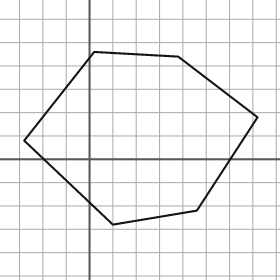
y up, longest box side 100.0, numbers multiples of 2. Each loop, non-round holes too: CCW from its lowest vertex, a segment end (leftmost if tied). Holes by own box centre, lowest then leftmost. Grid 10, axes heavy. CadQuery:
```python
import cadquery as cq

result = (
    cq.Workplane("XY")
    .moveTo(10.0, -28.0)
    .lineTo(46.0, -22.0)
    .lineTo(72.0, 18.0)
    .lineTo(38.0, 44.0)
    .lineTo(2.0, 46.0)
    .lineTo(-28.0, 8.0)
    .close()
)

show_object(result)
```